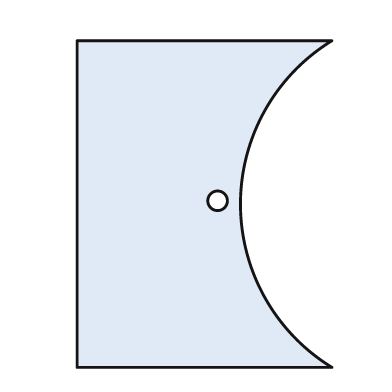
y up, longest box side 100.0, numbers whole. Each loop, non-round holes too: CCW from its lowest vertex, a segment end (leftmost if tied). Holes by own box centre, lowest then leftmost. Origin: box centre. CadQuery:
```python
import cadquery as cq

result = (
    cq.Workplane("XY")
    .moveTo(-39.0, -50.0)
    .lineTo(39.0, -50.0)
    .threePointArc((11.0, 0.0), (39.0, 50.0))
    .lineTo(-39.0, 50.0)
    .close()
    .moveTo(4.0, 1.0)
    .circle(3.0)
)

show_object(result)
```